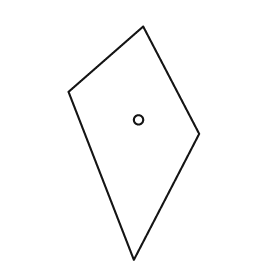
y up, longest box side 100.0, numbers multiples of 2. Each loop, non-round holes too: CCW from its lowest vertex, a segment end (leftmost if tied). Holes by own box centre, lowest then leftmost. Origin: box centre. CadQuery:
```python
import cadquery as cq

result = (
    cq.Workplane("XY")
    .moveTo(0.0, -50.0)
    .lineTo(28.0, 4.0)
    .lineTo(4.0, 50.0)
    .lineTo(-28.0, 22.0)
    .close()
    .moveTo(2.0, 10.0)
    .circle(2.0)
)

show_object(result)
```